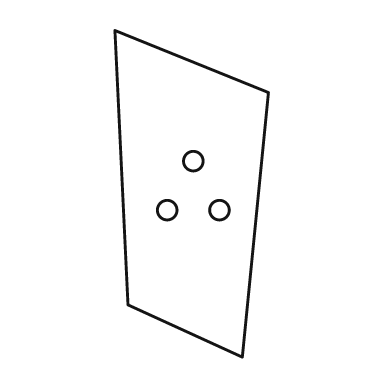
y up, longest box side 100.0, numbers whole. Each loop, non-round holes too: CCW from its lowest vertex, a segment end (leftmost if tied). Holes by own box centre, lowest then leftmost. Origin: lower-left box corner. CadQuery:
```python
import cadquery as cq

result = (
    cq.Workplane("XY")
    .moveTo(39.0, 0.0)
    .lineTo(47.0, 81.0)
    .lineTo(0.0, 100.0)
    .lineTo(4.0, 16.0)
    .close()
    .moveTo(16.0, 45.0)
    .circle(3.0)
    .moveTo(32.0, 45.0)
    .circle(3.0)
    .moveTo(24.0, 60.0)
    .circle(3.0)
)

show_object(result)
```